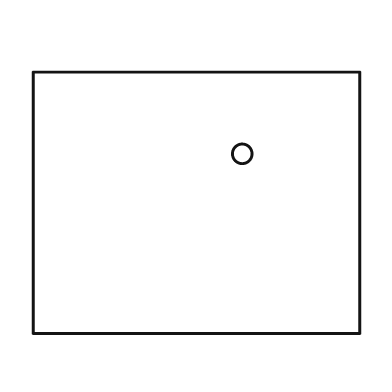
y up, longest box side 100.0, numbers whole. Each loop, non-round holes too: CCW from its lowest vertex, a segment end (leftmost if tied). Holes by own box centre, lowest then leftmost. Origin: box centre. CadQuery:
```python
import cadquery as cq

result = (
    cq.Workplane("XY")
    .moveTo(-50.0, -40.0)
    .lineTo(50.0, -40.0)
    .lineTo(50.0, 40.0)
    .lineTo(-50.0, 40.0)
    .close()
    .moveTo(14.0, 15.0)
    .circle(3.0)
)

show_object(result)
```